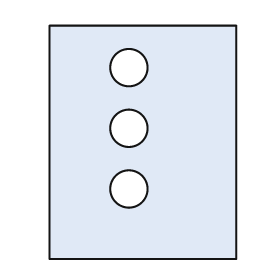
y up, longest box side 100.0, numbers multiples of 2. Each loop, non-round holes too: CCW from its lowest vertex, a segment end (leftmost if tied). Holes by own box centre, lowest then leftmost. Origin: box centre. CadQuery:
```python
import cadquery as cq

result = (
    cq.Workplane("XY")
    .moveTo(-40.0, -50.0)
    .lineTo(40.0, -50.0)
    .lineTo(40.0, 50.0)
    .lineTo(-40.0, 50.0)
    .close()
    .moveTo(-6.0, -20.0)
    .circle(8.0)
    .moveTo(-6.0, 6.0)
    .circle(8.0)
    .moveTo(-6.0, 32.0)
    .circle(8.0)
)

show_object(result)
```